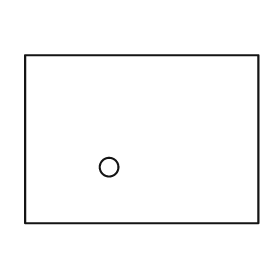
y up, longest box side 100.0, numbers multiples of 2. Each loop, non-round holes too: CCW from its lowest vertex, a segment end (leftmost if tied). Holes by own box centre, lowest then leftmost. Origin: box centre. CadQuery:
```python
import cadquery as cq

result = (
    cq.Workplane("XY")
    .moveTo(-50.0, -36.0)
    .lineTo(50.0, -36.0)
    .lineTo(50.0, 36.0)
    .lineTo(-50.0, 36.0)
    .close()
    .moveTo(-14.0, -12.0)
    .circle(4.0)
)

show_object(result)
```